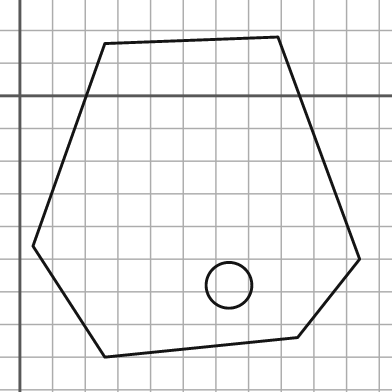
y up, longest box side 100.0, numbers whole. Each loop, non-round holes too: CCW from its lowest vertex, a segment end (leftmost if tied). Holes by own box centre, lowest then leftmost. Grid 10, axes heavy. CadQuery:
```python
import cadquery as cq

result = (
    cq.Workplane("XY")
    .moveTo(26.0, -80.0)
    .lineTo(85.0, -74.0)
    .lineTo(104.0, -50.0)
    .lineTo(79.0, 18.0)
    .lineTo(26.0, 16.0)
    .lineTo(4.0, -46.0)
    .close()
    .moveTo(64.0, -58.0)
    .circle(7.0)
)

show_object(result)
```